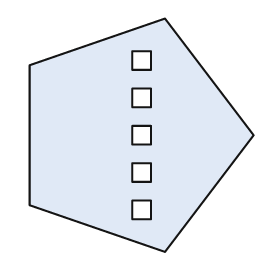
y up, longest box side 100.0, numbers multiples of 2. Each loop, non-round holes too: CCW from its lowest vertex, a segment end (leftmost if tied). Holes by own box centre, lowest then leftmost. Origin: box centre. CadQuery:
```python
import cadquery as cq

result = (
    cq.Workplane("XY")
    .moveTo(10.0, -50.0)
    .lineTo(48.0, 0.0)
    .lineTo(10.0, 50.0)
    .lineTo(-48.0, 30.0)
    .lineTo(-48.0, -30.0)
    .close()
    .moveTo(-4.0, -36.0)
    .lineTo(4.0, -36.0)
    .lineTo(4.0, -28.0)
    .lineTo(-4.0, -28.0)
    .close()
    .moveTo(-4.0, -20.0)
    .lineTo(4.0, -20.0)
    .lineTo(4.0, -12.0)
    .lineTo(-4.0, -12.0)
    .close()
    .moveTo(-4.0, -4.0)
    .lineTo(4.0, -4.0)
    .lineTo(4.0, 4.0)
    .lineTo(-4.0, 4.0)
    .close()
    .moveTo(-4.0, 12.0)
    .lineTo(4.0, 12.0)
    .lineTo(4.0, 20.0)
    .lineTo(-4.0, 20.0)
    .close()
    .moveTo(-4.0, 28.0)
    .lineTo(4.0, 28.0)
    .lineTo(4.0, 36.0)
    .lineTo(-4.0, 36.0)
    .close()
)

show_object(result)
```